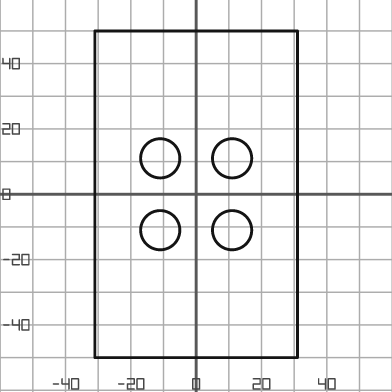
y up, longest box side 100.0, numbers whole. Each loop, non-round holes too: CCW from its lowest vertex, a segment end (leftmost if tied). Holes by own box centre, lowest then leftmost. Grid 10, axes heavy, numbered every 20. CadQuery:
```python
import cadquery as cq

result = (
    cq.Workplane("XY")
    .moveTo(-31.0, -50.0)
    .lineTo(31.0, -50.0)
    .lineTo(31.0, 50.0)
    .lineTo(-31.0, 50.0)
    .close()
    .moveTo(-11.0, -11.0)
    .circle(6.0)
    .moveTo(11.0, -11.0)
    .circle(6.0)
    .moveTo(-11.0, 11.0)
    .circle(6.0)
    .moveTo(11.0, 11.0)
    .circle(6.0)
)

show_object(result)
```